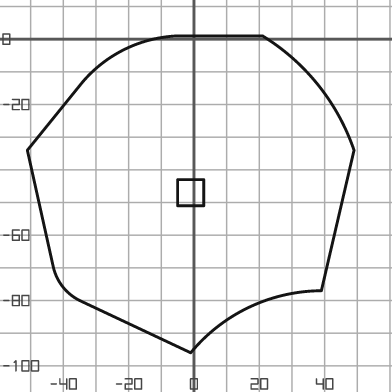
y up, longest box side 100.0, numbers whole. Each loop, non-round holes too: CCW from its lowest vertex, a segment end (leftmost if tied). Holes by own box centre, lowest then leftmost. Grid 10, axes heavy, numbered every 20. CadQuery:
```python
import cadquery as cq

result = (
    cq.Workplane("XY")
    .moveTo(-1.0, -96.0)
    .threePointArc((17.0, -82.0), (39.0, -77.0))
    .lineTo(49.0, -34.0)
    .threePointArc((38.0, -14.0), (21.0, 1.0))
    .lineTo(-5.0, 1.0)
    .threePointArc((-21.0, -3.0), (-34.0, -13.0))
    .lineTo(-51.0, -34.0)
    .lineTo(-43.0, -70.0)
    .threePointArc((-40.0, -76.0), (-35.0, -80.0))
    .close()
    .moveTo(-5.0, -51.0)
    .lineTo(3.0, -51.0)
    .lineTo(3.0, -43.0)
    .lineTo(-5.0, -43.0)
    .close()
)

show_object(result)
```